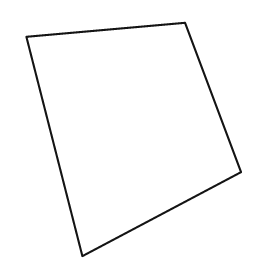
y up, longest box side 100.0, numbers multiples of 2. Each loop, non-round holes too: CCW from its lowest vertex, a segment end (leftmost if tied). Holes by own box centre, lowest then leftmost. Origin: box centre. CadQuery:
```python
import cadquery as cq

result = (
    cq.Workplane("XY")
    .moveTo(-22.0, -50.0)
    .lineTo(46.0, -14.0)
    .lineTo(22.0, 50.0)
    .lineTo(-46.0, 44.0)
    .close()
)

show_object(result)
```